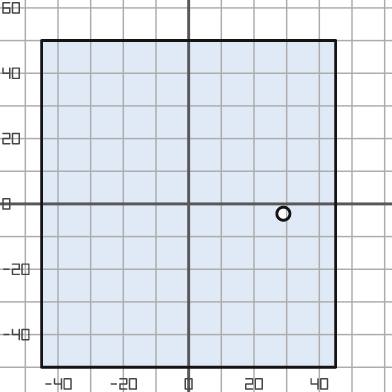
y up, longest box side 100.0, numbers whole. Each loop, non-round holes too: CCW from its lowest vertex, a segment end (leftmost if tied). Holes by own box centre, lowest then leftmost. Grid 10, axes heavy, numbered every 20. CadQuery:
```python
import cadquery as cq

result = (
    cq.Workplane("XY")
    .moveTo(-45.0, -50.0)
    .lineTo(45.0, -50.0)
    .lineTo(45.0, 50.0)
    .lineTo(-45.0, 50.0)
    .close()
    .moveTo(29.0, -3.0)
    .circle(2.0)
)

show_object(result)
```